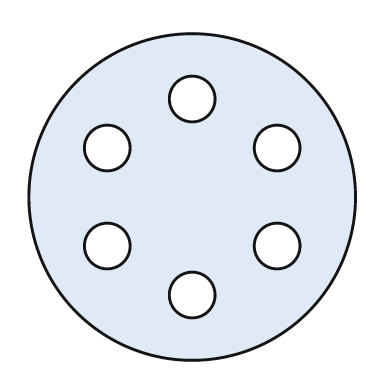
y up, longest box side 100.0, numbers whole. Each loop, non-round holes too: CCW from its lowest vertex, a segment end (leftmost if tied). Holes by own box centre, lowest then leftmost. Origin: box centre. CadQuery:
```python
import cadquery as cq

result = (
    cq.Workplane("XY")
    .moveTo(0.0, 0.0)
    .circle(50.0)
    .moveTo(0.0, -30.0)
    .circle(7.0)
    .moveTo(-26.0, -15.0)
    .circle(7.0)
    .moveTo(26.0, -15.0)
    .circle(7.0)
    .moveTo(-26.0, 15.0)
    .circle(7.0)
    .moveTo(26.0, 15.0)
    .circle(7.0)
    .moveTo(0.0, 30.0)
    .circle(7.0)
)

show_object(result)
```